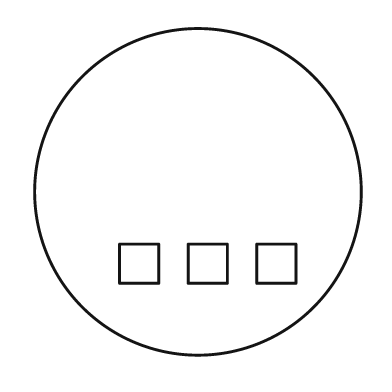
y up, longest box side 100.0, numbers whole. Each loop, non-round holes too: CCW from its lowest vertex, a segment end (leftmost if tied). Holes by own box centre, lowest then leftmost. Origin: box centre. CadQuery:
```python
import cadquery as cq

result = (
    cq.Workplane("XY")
    .moveTo(0.0, 0.0)
    .circle(50.0)
    .moveTo(-24.0, -28.0)
    .lineTo(-12.0, -28.0)
    .lineTo(-12.0, -16.0)
    .lineTo(-24.0, -16.0)
    .close()
    .moveTo(-3.0, -28.0)
    .lineTo(9.0, -28.0)
    .lineTo(9.0, -16.0)
    .lineTo(-3.0, -16.0)
    .close()
    .moveTo(18.0, -28.0)
    .lineTo(30.0, -28.0)
    .lineTo(30.0, -16.0)
    .lineTo(18.0, -16.0)
    .close()
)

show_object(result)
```